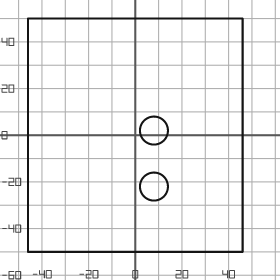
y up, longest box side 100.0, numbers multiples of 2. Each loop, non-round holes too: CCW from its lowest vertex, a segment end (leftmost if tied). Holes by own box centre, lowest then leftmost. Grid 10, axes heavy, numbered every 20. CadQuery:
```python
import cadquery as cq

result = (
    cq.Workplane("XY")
    .moveTo(-46.0, -50.0)
    .lineTo(46.0, -50.0)
    .lineTo(46.0, 50.0)
    .lineTo(-46.0, 50.0)
    .close()
    .moveTo(8.0, -22.0)
    .circle(6.0)
    .moveTo(8.0, 2.0)
    .circle(6.0)
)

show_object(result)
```